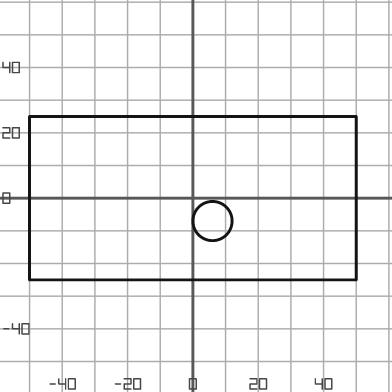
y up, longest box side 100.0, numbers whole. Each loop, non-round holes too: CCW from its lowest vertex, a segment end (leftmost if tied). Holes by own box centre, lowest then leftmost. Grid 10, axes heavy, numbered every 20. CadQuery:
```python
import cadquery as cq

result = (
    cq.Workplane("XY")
    .moveTo(-50.0, -25.0)
    .lineTo(50.0, -25.0)
    .lineTo(50.0, 25.0)
    .lineTo(-50.0, 25.0)
    .close()
    .moveTo(6.0, -7.0)
    .circle(6.0)
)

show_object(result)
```